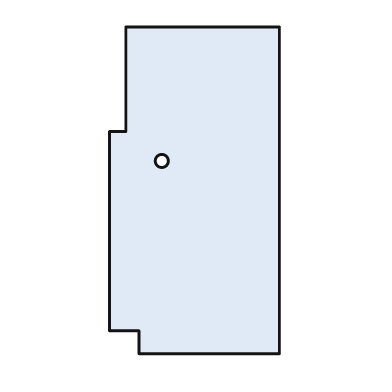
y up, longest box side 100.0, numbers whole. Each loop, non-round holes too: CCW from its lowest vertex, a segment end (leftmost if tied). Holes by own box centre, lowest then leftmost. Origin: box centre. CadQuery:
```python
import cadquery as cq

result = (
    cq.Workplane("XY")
    .moveTo(-17.0, -50.0)
    .lineTo(26.0, -50.0)
    .lineTo(26.0, 50.0)
    .lineTo(-21.0, 50.0)
    .lineTo(-21.0, 18.0)
    .lineTo(-26.0, 18.0)
    .lineTo(-26.0, -43.0)
    .lineTo(-17.0, -43.0)
    .close()
    .moveTo(-10.0, 9.0)
    .circle(2.0)
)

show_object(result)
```